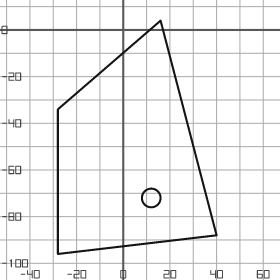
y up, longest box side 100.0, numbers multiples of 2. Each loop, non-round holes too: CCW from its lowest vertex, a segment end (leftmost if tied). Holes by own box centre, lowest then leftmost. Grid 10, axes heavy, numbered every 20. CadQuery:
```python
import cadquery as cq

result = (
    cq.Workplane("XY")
    .moveTo(-28.0, -96.0)
    .lineTo(40.0, -88.0)
    .lineTo(16.0, 4.0)
    .lineTo(-28.0, -34.0)
    .close()
    .moveTo(12.0, -72.0)
    .circle(4.0)
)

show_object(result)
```